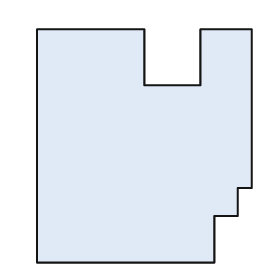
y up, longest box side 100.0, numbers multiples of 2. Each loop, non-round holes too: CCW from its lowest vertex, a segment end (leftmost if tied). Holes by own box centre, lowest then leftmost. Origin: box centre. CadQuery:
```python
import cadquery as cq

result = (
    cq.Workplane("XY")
    .moveTo(-46.0, -50.0)
    .lineTo(30.0, -50.0)
    .lineTo(30.0, -30.0)
    .lineTo(40.0, -30.0)
    .lineTo(40.0, -18.0)
    .lineTo(46.0, -18.0)
    .lineTo(46.0, 50.0)
    .lineTo(24.0, 50.0)
    .lineTo(24.0, 26.0)
    .lineTo(0.0, 26.0)
    .lineTo(0.0, 50.0)
    .lineTo(-46.0, 50.0)
    .close()
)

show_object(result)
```